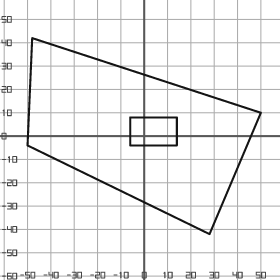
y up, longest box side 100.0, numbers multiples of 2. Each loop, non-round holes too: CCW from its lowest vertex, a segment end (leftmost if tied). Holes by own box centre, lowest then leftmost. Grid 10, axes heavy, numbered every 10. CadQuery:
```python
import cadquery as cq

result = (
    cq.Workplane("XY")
    .moveTo(28.0, -42.0)
    .lineTo(50.0, 10.0)
    .lineTo(-48.0, 42.0)
    .lineTo(-50.0, -4.0)
    .close()
    .moveTo(-6.0, -4.0)
    .lineTo(14.0, -4.0)
    .lineTo(14.0, 8.0)
    .lineTo(-6.0, 8.0)
    .close()
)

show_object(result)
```